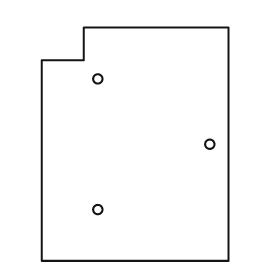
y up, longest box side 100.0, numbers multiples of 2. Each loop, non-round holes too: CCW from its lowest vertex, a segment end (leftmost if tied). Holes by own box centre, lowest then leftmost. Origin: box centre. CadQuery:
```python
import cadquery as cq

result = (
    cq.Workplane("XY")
    .moveTo(-40.0, -50.0)
    .lineTo(40.0, -50.0)
    .lineTo(40.0, 50.0)
    .lineTo(-22.0, 50.0)
    .lineTo(-22.0, 36.0)
    .lineTo(-40.0, 36.0)
    .close()
    .moveTo(-16.0, -28.0)
    .circle(2.0)
    .moveTo(32.0, 0.0)
    .circle(2.0)
    .moveTo(-16.0, 28.0)
    .circle(2.0)
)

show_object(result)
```